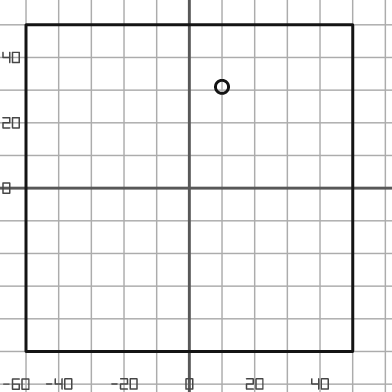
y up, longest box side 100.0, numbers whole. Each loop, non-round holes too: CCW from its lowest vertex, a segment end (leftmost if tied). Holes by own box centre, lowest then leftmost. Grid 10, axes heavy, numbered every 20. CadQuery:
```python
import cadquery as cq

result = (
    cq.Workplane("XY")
    .moveTo(-50.0, -50.0)
    .lineTo(50.0, -50.0)
    .lineTo(50.0, 50.0)
    .lineTo(-50.0, 50.0)
    .close()
    .moveTo(10.0, 31.0)
    .circle(2.0)
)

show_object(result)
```